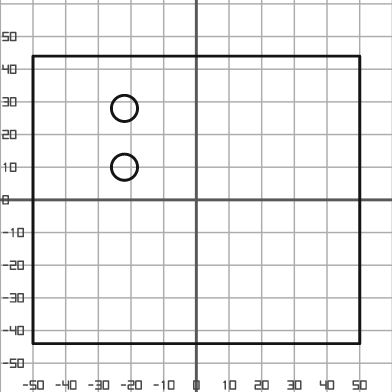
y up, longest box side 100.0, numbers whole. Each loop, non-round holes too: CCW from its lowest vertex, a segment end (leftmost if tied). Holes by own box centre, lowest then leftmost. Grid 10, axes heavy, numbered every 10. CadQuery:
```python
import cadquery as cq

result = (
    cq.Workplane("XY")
    .moveTo(-50.0, -44.0)
    .lineTo(50.0, -44.0)
    .lineTo(50.0, 44.0)
    .lineTo(-50.0, 44.0)
    .close()
    .moveTo(-22.0, 10.0)
    .circle(4.0)
    .moveTo(-22.0, 28.0)
    .circle(4.0)
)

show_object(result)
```